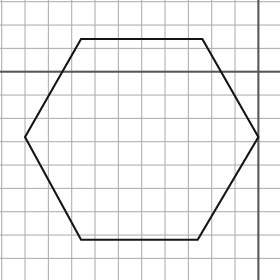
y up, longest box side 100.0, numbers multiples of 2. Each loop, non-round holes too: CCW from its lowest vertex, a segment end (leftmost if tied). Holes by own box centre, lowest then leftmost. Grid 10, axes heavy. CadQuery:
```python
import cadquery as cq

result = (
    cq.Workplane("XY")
    .moveTo(-76.0, -72.0)
    .lineTo(-26.0, -72.0)
    .lineTo(0.0, -28.0)
    .lineTo(-24.0, 14.0)
    .lineTo(-76.0, 14.0)
    .lineTo(-100.0, -28.0)
    .close()
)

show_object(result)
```